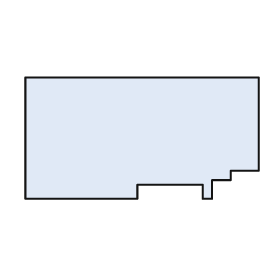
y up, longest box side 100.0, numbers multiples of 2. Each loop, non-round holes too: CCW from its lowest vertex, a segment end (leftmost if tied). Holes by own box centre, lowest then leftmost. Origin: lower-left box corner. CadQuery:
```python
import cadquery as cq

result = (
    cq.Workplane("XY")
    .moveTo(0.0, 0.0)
    .lineTo(48.0, 0.0)
    .lineTo(48.0, 6.0)
    .lineTo(76.0, 6.0)
    .lineTo(76.0, 0.0)
    .lineTo(80.0, 0.0)
    .lineTo(80.0, 8.0)
    .lineTo(88.0, 8.0)
    .lineTo(88.0, 12.0)
    .lineTo(100.0, 12.0)
    .lineTo(100.0, 52.0)
    .lineTo(0.0, 52.0)
    .close()
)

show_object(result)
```